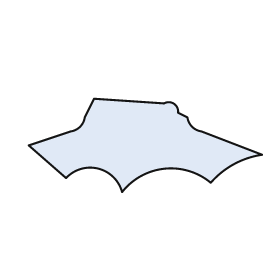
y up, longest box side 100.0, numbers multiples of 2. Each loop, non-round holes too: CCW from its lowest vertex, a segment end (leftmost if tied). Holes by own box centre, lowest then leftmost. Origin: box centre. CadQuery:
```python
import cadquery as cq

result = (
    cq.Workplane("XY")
    .moveTo(-10.0, -20.0)
    .threePointArc((8.0, -10.0), (28.0, -16.0))
    .threePointArc((38.0, -8.0), (50.0, -4.0))
    .lineTo(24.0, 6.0)
    .threePointArc((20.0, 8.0), (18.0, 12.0))
    .lineTo(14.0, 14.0)
    .threePointArc((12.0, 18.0), (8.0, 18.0))
    .lineTo(-22.0, 20.0)
    .lineTo(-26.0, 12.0)
    .threePointArc((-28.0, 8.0), (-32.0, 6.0))
    .lineTo(-50.0, 0.0)
    .lineTo(-34.0, -14.0)
    .threePointArc((-20.0, -10.0), (-10.0, -20.0))
    .close()
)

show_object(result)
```